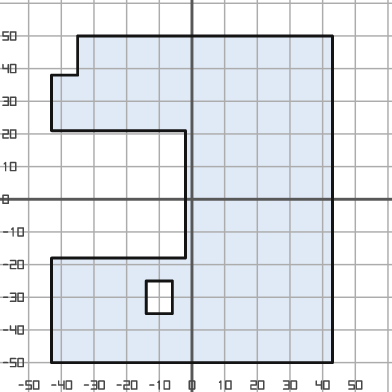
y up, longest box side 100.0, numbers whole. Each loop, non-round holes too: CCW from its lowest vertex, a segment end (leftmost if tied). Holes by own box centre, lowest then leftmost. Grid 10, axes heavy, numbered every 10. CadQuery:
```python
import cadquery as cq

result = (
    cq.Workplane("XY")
    .moveTo(-43.0, -50.0)
    .lineTo(43.0, -50.0)
    .lineTo(43.0, 50.0)
    .lineTo(-35.0, 50.0)
    .lineTo(-35.0, 38.0)
    .lineTo(-43.0, 38.0)
    .lineTo(-43.0, 21.0)
    .lineTo(-2.0, 21.0)
    .lineTo(-2.0, -18.0)
    .lineTo(-43.0, -18.0)
    .close()
    .moveTo(-14.0, -35.0)
    .lineTo(-6.0, -35.0)
    .lineTo(-6.0, -25.0)
    .lineTo(-14.0, -25.0)
    .close()
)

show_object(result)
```